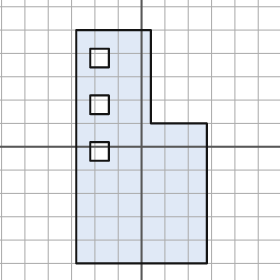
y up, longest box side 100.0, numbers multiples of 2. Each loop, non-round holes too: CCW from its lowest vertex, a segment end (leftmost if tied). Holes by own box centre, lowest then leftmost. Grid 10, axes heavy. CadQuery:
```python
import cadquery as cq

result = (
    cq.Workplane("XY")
    .moveTo(-28.0, -50.0)
    .lineTo(28.0, -50.0)
    .lineTo(28.0, 10.0)
    .lineTo(4.0, 10.0)
    .lineTo(4.0, 50.0)
    .lineTo(-28.0, 50.0)
    .close()
    .moveTo(-22.0, -6.0)
    .lineTo(-14.0, -6.0)
    .lineTo(-14.0, 2.0)
    .lineTo(-22.0, 2.0)
    .close()
    .moveTo(-22.0, 14.0)
    .lineTo(-14.0, 14.0)
    .lineTo(-14.0, 22.0)
    .lineTo(-22.0, 22.0)
    .close()
    .moveTo(-22.0, 34.0)
    .lineTo(-14.0, 34.0)
    .lineTo(-14.0, 42.0)
    .lineTo(-22.0, 42.0)
    .close()
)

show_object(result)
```